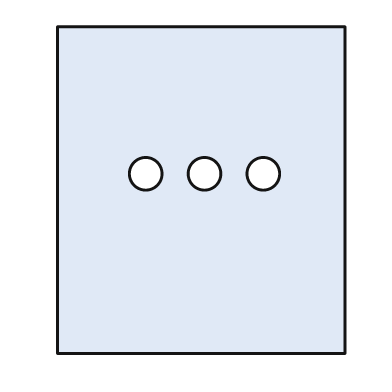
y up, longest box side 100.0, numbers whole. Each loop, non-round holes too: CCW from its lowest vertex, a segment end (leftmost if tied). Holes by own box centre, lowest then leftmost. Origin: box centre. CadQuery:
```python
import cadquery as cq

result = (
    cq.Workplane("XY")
    .moveTo(-44.0, -50.0)
    .lineTo(44.0, -50.0)
    .lineTo(44.0, 50.0)
    .lineTo(-44.0, 50.0)
    .close()
    .moveTo(-17.0, 5.0)
    .circle(5.0)
    .moveTo(1.0, 5.0)
    .circle(5.0)
    .moveTo(19.0, 5.0)
    .circle(5.0)
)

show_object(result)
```